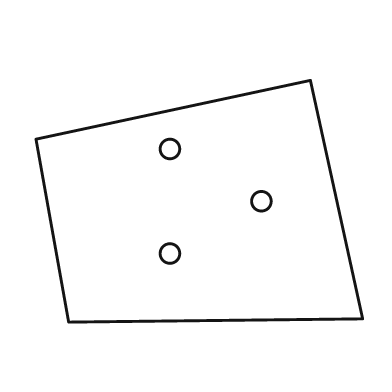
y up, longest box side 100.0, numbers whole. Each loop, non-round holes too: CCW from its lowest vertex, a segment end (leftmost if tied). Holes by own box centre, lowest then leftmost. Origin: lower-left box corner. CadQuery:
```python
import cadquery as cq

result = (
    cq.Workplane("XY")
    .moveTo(10.0, 0.0)
    .lineTo(100.0, 1.0)
    .lineTo(84.0, 74.0)
    .lineTo(0.0, 56.0)
    .close()
    .moveTo(41.0, 21.0)
    .circle(3.0)
    .moveTo(69.0, 37.0)
    .circle(3.0)
    .moveTo(41.0, 53.0)
    .circle(3.0)
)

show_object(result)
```